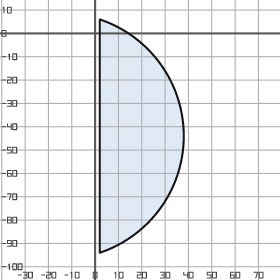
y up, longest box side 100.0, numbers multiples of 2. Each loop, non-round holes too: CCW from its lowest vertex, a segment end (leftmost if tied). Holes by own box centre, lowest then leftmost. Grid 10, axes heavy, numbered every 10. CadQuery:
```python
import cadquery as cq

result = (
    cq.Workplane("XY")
    .moveTo(2.0, -94.0)
    .threePointArc((38.0, -44.0), (2.0, 6.0))
    .close()
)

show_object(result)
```